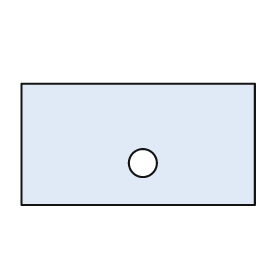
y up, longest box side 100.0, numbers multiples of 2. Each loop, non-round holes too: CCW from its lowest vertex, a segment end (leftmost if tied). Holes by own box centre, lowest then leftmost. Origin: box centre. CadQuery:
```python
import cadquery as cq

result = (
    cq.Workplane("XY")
    .moveTo(-50.0, -26.0)
    .lineTo(50.0, -26.0)
    .lineTo(50.0, 26.0)
    .lineTo(-50.0, 26.0)
    .close()
    .moveTo(2.0, -8.0)
    .circle(6.0)
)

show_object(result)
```